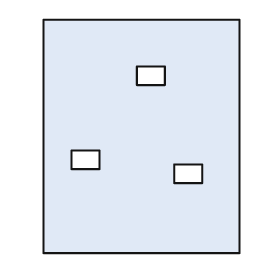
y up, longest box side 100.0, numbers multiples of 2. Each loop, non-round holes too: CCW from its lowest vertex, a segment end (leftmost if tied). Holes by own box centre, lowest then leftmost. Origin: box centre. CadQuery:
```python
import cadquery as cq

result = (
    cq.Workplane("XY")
    .moveTo(-42.0, -50.0)
    .lineTo(42.0, -50.0)
    .lineTo(42.0, 50.0)
    .lineTo(-42.0, 50.0)
    .close()
    .moveTo(14.0, -20.0)
    .lineTo(26.0, -20.0)
    .lineTo(26.0, -12.0)
    .lineTo(14.0, -12.0)
    .close()
    .moveTo(-30.0, -14.0)
    .lineTo(-18.0, -14.0)
    .lineTo(-18.0, -6.0)
    .lineTo(-30.0, -6.0)
    .close()
    .moveTo(-2.0, 22.0)
    .lineTo(10.0, 22.0)
    .lineTo(10.0, 30.0)
    .lineTo(-2.0, 30.0)
    .close()
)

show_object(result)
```